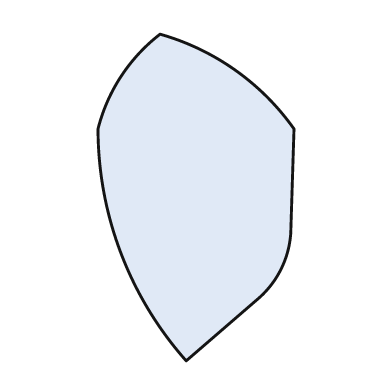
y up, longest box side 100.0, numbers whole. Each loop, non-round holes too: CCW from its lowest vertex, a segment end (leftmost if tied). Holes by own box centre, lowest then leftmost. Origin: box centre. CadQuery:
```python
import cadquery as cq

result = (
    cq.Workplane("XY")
    .moveTo(-3.0, -50.0)
    .lineTo(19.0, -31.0)
    .threePointArc((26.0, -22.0), (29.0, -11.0))
    .lineTo(30.0, 21.0)
    .threePointArc((12.0, 39.0), (-11.0, 50.0))
    .threePointArc((-23.0, 37.0), (-30.0, 21.0))
    .threePointArc((-23.0, -17.0), (-3.0, -50.0))
    .close()
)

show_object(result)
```